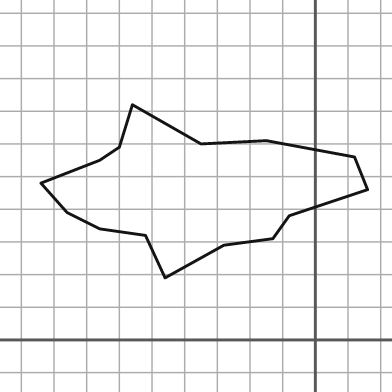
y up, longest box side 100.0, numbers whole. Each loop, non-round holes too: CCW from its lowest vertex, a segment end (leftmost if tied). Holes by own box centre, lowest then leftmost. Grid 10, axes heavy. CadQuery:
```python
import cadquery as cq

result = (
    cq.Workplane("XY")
    .moveTo(-46.0, 19.0)
    .lineTo(-28.0, 29.0)
    .lineTo(-13.0, 31.0)
    .lineTo(-8.0, 38.0)
    .lineTo(16.0, 46.0)
    .lineTo(12.0, 56.0)
    .lineTo(-15.0, 61.0)
    .lineTo(-35.0, 60.0)
    .lineTo(-56.0, 72.0)
    .lineTo(-60.0, 59.0)
    .lineTo(-66.0, 55.0)
    .lineTo(-84.0, 48.0)
    .lineTo(-76.0, 39.0)
    .lineTo(-66.0, 34.0)
    .lineTo(-52.0, 32.0)
    .close()
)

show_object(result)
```